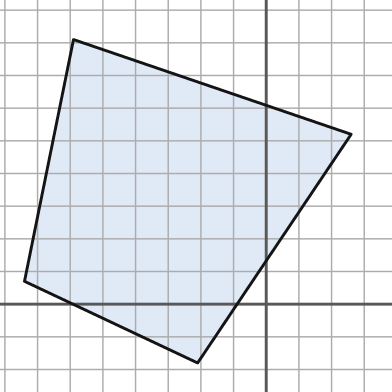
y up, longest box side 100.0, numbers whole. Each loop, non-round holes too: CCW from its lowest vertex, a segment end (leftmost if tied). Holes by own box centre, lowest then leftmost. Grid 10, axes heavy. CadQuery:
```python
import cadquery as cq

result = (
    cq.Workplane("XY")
    .moveTo(-21.0, -18.0)
    .lineTo(26.0, 52.0)
    .lineTo(-59.0, 81.0)
    .lineTo(-74.0, 7.0)
    .close()
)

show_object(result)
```